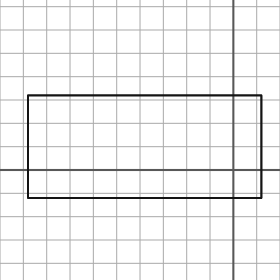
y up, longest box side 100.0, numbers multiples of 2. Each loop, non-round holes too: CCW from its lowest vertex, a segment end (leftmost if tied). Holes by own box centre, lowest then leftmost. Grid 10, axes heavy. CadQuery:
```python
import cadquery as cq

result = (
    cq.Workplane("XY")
    .moveTo(-88.0, -12.0)
    .lineTo(12.0, -12.0)
    .lineTo(12.0, 32.0)
    .lineTo(-88.0, 32.0)
    .close()
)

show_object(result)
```